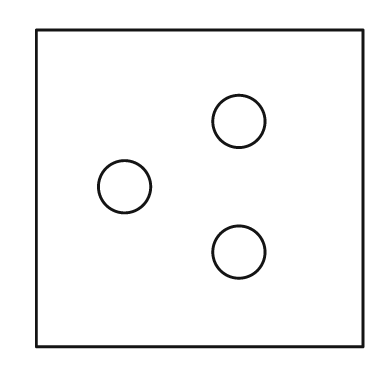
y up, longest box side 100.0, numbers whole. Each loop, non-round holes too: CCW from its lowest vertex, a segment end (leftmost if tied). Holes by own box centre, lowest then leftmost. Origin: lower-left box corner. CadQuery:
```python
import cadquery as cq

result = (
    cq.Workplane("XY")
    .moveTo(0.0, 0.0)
    .lineTo(100.0, 0.0)
    .lineTo(100.0, 97.0)
    .lineTo(0.0, 97.0)
    .close()
    .moveTo(62.0, 29.0)
    .circle(8.0)
    .moveTo(27.0, 49.0)
    .circle(8.0)
    .moveTo(62.0, 69.0)
    .circle(8.0)
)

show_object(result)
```